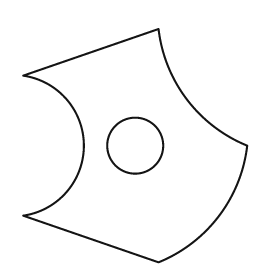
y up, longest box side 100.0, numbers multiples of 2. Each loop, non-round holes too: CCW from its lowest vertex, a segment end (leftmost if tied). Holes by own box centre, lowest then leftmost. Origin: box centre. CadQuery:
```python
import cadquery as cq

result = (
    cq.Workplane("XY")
    .moveTo(10.0, -50.0)
    .threePointArc((36.0, -30.0), (48.0, 0.0))
    .threePointArc((22.0, 20.0), (10.0, 50.0))
    .lineTo(-48.0, 30.0)
    .threePointArc((-22.0, 0.0), (-48.0, -30.0))
    .close()
    .moveTo(0.0, 0.0)
    .circle(12.0)
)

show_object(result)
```